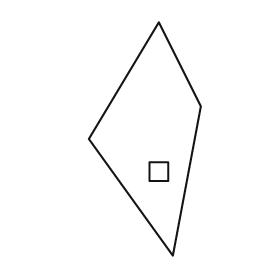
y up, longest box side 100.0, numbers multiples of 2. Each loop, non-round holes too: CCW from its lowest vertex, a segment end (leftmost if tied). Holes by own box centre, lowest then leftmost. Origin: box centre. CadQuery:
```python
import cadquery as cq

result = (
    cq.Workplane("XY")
    .moveTo(12.0, -50.0)
    .lineTo(24.0, 14.0)
    .lineTo(6.0, 50.0)
    .lineTo(-24.0, 0.0)
    .close()
    .moveTo(2.0, -18.0)
    .lineTo(10.0, -18.0)
    .lineTo(10.0, -10.0)
    .lineTo(2.0, -10.0)
    .close()
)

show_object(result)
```